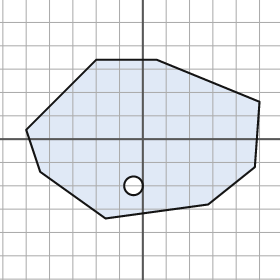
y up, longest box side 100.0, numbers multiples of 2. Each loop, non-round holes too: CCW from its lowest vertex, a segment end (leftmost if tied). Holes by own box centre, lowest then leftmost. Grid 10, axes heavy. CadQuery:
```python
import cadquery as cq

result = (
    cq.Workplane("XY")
    .moveTo(-16.0, -34.0)
    .lineTo(28.0, -28.0)
    .lineTo(48.0, -12.0)
    .lineTo(50.0, 16.0)
    .lineTo(6.0, 34.0)
    .lineTo(-20.0, 34.0)
    .lineTo(-50.0, 4.0)
    .lineTo(-44.0, -14.0)
    .close()
    .moveTo(-4.0, -20.0)
    .circle(4.0)
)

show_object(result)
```